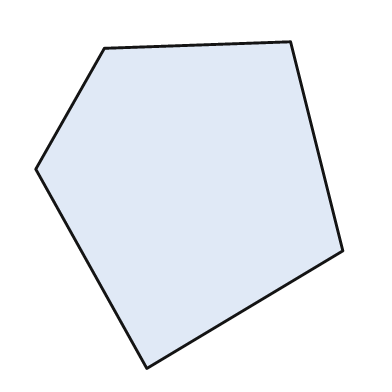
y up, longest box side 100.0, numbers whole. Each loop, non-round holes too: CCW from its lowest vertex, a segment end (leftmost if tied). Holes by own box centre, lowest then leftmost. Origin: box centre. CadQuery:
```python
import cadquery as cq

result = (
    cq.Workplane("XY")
    .moveTo(-13.0, -50.0)
    .lineTo(47.0, -14.0)
    .lineTo(31.0, 50.0)
    .lineTo(-26.0, 48.0)
    .lineTo(-47.0, 11.0)
    .close()
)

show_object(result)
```